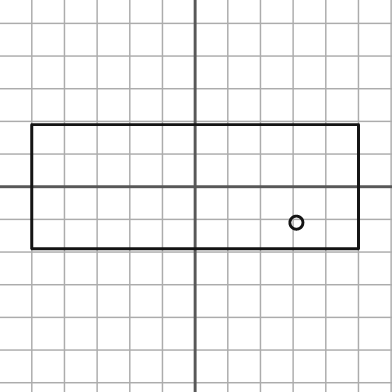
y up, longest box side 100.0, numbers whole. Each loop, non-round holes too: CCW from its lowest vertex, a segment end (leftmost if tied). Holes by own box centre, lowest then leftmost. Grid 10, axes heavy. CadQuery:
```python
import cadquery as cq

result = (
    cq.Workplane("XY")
    .moveTo(-50.0, -19.0)
    .lineTo(50.0, -19.0)
    .lineTo(50.0, 19.0)
    .lineTo(-50.0, 19.0)
    .close()
    .moveTo(31.0, -11.0)
    .circle(2.0)
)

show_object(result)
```